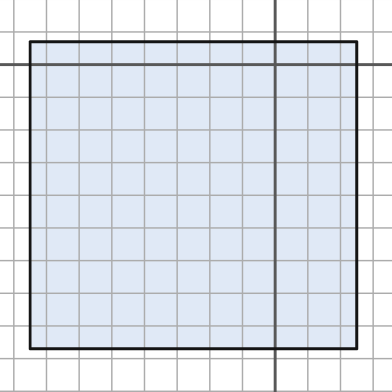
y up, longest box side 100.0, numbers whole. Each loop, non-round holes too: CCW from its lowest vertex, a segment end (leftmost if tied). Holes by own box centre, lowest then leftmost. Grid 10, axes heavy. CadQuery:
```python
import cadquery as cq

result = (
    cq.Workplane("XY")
    .moveTo(-75.0, -87.0)
    .lineTo(25.0, -87.0)
    .lineTo(25.0, 7.0)
    .lineTo(-75.0, 7.0)
    .close()
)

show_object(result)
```